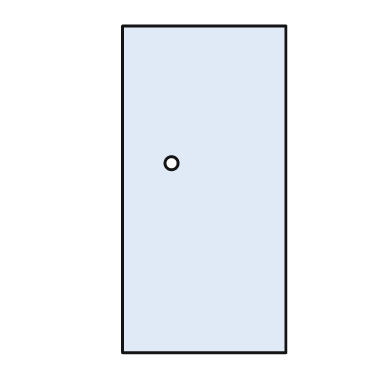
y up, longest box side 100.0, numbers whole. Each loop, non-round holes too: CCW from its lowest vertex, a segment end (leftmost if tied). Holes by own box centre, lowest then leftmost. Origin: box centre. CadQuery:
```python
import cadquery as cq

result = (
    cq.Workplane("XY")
    .moveTo(-25.0, -50.0)
    .lineTo(25.0, -50.0)
    .lineTo(25.0, 50.0)
    .lineTo(-25.0, 50.0)
    .close()
    .moveTo(-10.0, 8.0)
    .circle(2.0)
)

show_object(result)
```